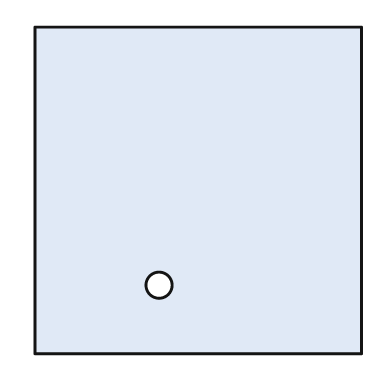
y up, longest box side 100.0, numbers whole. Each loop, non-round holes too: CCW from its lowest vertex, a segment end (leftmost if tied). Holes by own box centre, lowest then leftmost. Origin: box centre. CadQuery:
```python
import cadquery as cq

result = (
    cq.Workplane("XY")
    .moveTo(-50.0, -50.0)
    .lineTo(50.0, -50.0)
    .lineTo(50.0, 50.0)
    .lineTo(-50.0, 50.0)
    .close()
    .moveTo(-12.0, -29.0)
    .circle(4.0)
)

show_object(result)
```